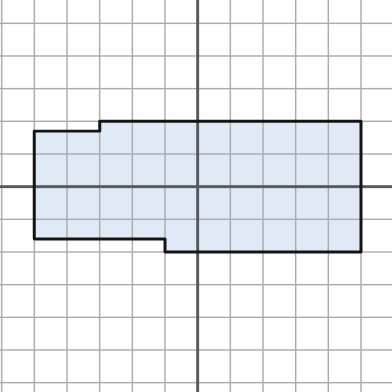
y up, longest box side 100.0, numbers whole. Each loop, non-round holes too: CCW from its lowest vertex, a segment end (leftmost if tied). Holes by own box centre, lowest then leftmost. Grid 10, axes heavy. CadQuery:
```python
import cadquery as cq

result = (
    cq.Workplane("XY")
    .moveTo(-10.0, -20.0)
    .lineTo(50.0, -20.0)
    .lineTo(50.0, 20.0)
    .lineTo(-30.0, 20.0)
    .lineTo(-30.0, 17.0)
    .lineTo(-50.0, 17.0)
    .lineTo(-50.0, -16.0)
    .lineTo(-10.0, -16.0)
    .close()
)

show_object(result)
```